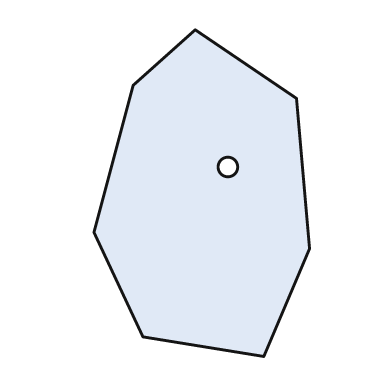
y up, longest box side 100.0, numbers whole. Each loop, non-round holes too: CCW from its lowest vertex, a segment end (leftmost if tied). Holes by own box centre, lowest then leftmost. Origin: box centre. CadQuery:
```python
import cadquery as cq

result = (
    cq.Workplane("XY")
    .moveTo(19.0, -50.0)
    .lineTo(33.0, -17.0)
    .lineTo(29.0, 29.0)
    .lineTo(-2.0, 50.0)
    .lineTo(-21.0, 33.0)
    .lineTo(-33.0, -12.0)
    .lineTo(-18.0, -44.0)
    .close()
    .moveTo(8.0, 8.0)
    .circle(3.0)
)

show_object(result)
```